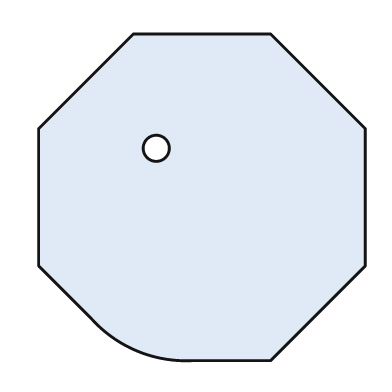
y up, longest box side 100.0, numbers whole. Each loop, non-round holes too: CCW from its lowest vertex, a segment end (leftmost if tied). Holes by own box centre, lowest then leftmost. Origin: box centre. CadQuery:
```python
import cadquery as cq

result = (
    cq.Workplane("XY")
    .moveTo(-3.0, -50.0)
    .lineTo(21.0, -50.0)
    .lineTo(50.0, -21.0)
    .lineTo(50.0, 21.0)
    .lineTo(21.0, 50.0)
    .lineTo(-21.0, 50.0)
    .lineTo(-50.0, 21.0)
    .lineTo(-50.0, -21.0)
    .lineTo(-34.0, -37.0)
    .threePointArc((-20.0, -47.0), (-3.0, -50.0))
    .close()
    .moveTo(-14.0, 15.0)
    .circle(4.0)
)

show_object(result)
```